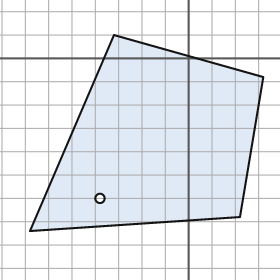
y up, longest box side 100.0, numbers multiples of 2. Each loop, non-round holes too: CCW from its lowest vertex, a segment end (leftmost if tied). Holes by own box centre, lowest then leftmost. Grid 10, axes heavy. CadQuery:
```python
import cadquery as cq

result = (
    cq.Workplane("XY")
    .moveTo(-68.0, -74.0)
    .lineTo(22.0, -68.0)
    .lineTo(32.0, -8.0)
    .lineTo(-32.0, 10.0)
    .close()
    .moveTo(-38.0, -60.0)
    .circle(2.0)
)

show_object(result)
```